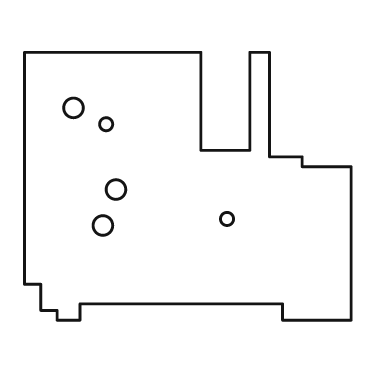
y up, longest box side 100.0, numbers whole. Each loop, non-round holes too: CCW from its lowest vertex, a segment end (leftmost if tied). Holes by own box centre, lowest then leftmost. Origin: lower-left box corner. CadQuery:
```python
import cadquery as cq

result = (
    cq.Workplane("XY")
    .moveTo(10.0, 0.0)
    .lineTo(17.0, 0.0)
    .lineTo(17.0, 5.0)
    .lineTo(79.0, 5.0)
    .lineTo(79.0, 0.0)
    .lineTo(100.0, 0.0)
    .lineTo(100.0, 47.0)
    .lineTo(85.0, 47.0)
    .lineTo(85.0, 50.0)
    .lineTo(75.0, 50.0)
    .lineTo(75.0, 82.0)
    .lineTo(69.0, 82.0)
    .lineTo(69.0, 52.0)
    .lineTo(54.0, 52.0)
    .lineTo(54.0, 82.0)
    .lineTo(0.0, 82.0)
    .lineTo(0.0, 11.0)
    .lineTo(5.0, 11.0)
    .lineTo(5.0, 3.0)
    .lineTo(10.0, 3.0)
    .close()
    .moveTo(24.0, 29.0)
    .circle(3.0)
    .moveTo(62.0, 31.0)
    .circle(2.0)
    .moveTo(28.0, 40.0)
    .circle(3.0)
    .moveTo(25.0, 60.0)
    .circle(2.0)
    .moveTo(15.0, 65.0)
    .circle(3.0)
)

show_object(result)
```